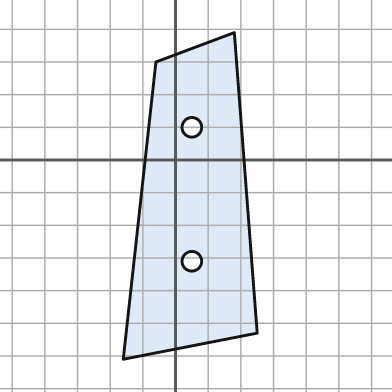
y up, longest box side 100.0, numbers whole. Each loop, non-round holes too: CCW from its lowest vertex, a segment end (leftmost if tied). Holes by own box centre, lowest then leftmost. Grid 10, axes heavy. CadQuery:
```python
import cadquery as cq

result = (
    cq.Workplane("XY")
    .moveTo(-16.0, -61.0)
    .lineTo(25.0, -53.0)
    .lineTo(18.0, 39.0)
    .lineTo(-6.0, 30.0)
    .close()
    .moveTo(5.0, -31.0)
    .circle(3.0)
    .moveTo(5.0, 10.0)
    .circle(3.0)
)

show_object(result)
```